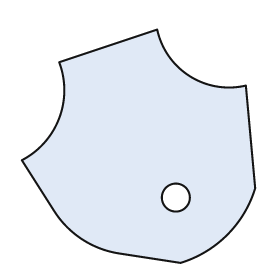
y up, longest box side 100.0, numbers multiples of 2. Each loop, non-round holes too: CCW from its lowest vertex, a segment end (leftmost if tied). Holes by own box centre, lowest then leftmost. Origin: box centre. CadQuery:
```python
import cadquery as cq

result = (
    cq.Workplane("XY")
    .moveTo(18.0, -50.0)
    .threePointArc((38.0, -38.0), (50.0, -18.0))
    .lineTo(46.0, 26.0)
    .threePointArc((22.0, 30.0), (8.0, 50.0))
    .lineTo(-34.0, 36.0)
    .threePointArc((-34.0, 12.0), (-50.0, -6.0))
    .lineTo(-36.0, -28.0)
    .threePointArc((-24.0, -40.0), (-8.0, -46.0))
    .close()
    .moveTo(16.0, -22.0)
    .circle(6.0)
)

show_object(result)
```